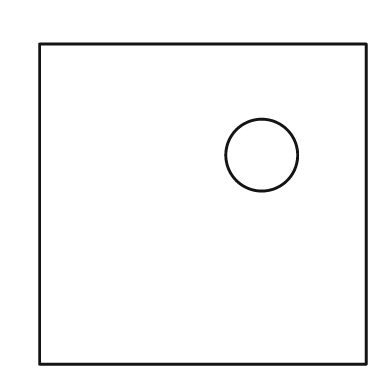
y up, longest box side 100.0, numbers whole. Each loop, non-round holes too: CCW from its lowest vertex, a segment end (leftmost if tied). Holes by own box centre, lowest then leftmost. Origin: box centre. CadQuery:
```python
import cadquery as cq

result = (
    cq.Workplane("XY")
    .moveTo(-50.0, -49.0)
    .lineTo(50.0, -49.0)
    .lineTo(50.0, 49.0)
    .lineTo(-50.0, 49.0)
    .close()
    .moveTo(18.0, 15.0)
    .circle(11.0)
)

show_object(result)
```